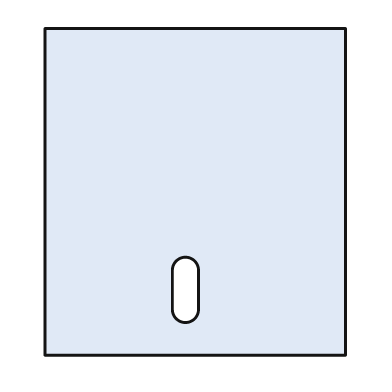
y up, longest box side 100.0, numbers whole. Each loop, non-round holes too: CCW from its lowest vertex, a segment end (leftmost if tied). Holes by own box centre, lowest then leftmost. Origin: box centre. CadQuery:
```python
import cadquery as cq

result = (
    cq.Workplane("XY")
    .moveTo(-46.0, -50.0)
    .lineTo(46.0, -50.0)
    .lineTo(46.0, 50.0)
    .lineTo(-46.0, 50.0)
    .close()
    .moveTo(-7.0, -36.0)
    .threePointArc((-3.0, -40.0), (1.0, -36.0))
    .lineTo(1.0, -24.0)
    .threePointArc((-3.0, -20.0), (-7.0, -24.0))
    .close()
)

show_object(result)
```